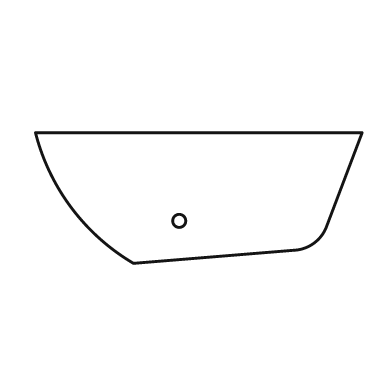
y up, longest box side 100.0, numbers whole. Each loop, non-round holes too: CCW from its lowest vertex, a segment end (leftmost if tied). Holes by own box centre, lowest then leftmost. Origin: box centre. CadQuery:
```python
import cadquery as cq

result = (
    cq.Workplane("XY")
    .moveTo(-20.0, -20.0)
    .lineTo(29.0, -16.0)
    .threePointArc((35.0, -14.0), (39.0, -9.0))
    .lineTo(50.0, 20.0)
    .lineTo(-50.0, 20.0)
    .threePointArc((-39.0, -3.0), (-20.0, -20.0))
    .close()
    .moveTo(-6.0, -7.0)
    .circle(2.0)
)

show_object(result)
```